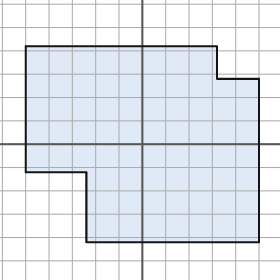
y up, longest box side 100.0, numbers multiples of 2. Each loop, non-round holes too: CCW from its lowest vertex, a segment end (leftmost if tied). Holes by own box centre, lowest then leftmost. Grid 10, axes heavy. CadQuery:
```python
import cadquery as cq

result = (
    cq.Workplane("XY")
    .moveTo(-24.0, -42.0)
    .lineTo(50.0, -42.0)
    .lineTo(50.0, 28.0)
    .lineTo(32.0, 28.0)
    .lineTo(32.0, 42.0)
    .lineTo(-50.0, 42.0)
    .lineTo(-50.0, -12.0)
    .lineTo(-24.0, -12.0)
    .close()
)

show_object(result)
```